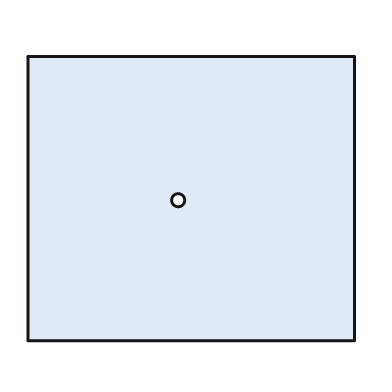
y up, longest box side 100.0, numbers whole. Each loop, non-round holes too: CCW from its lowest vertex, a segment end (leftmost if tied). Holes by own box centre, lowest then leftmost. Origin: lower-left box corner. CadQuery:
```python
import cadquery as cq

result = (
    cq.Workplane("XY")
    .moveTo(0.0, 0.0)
    .lineTo(100.0, 0.0)
    .lineTo(100.0, 87.0)
    .lineTo(0.0, 87.0)
    .close()
    .moveTo(46.0, 43.0)
    .circle(2.0)
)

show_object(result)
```